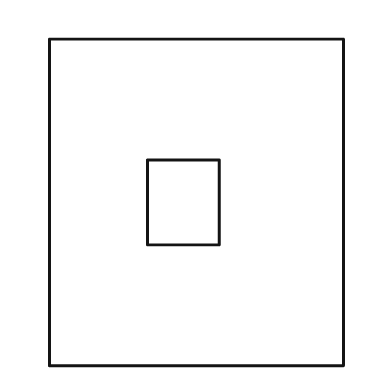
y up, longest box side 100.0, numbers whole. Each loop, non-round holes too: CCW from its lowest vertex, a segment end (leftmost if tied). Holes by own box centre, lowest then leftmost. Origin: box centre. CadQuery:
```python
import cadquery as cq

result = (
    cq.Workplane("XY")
    .moveTo(-45.0, -50.0)
    .lineTo(45.0, -50.0)
    .lineTo(45.0, 50.0)
    .lineTo(-45.0, 50.0)
    .close()
    .moveTo(-15.0, -13.0)
    .lineTo(7.0, -13.0)
    .lineTo(7.0, 13.0)
    .lineTo(-15.0, 13.0)
    .close()
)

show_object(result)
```